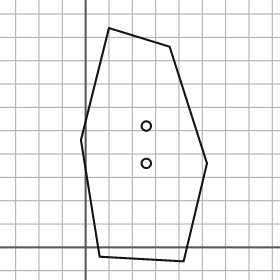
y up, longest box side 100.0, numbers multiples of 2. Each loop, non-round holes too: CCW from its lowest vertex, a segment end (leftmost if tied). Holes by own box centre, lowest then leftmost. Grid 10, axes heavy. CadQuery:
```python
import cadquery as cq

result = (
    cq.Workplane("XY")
    .moveTo(42.0, -6.0)
    .lineTo(52.0, 36.0)
    .lineTo(36.0, 86.0)
    .lineTo(10.0, 94.0)
    .lineTo(-2.0, 46.0)
    .lineTo(6.0, -4.0)
    .close()
    .moveTo(26.0, 36.0)
    .circle(2.0)
    .moveTo(26.0, 52.0)
    .circle(2.0)
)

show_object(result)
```